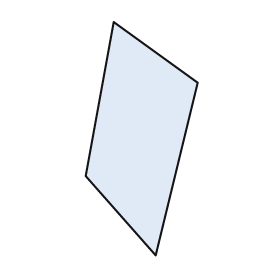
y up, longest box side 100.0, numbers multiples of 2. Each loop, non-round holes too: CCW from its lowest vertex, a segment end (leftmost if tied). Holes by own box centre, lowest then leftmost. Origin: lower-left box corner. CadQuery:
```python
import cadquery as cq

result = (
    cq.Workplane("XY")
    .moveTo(30.0, 0.0)
    .lineTo(48.0, 74.0)
    .lineTo(12.0, 100.0)
    .lineTo(0.0, 34.0)
    .close()
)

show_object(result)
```